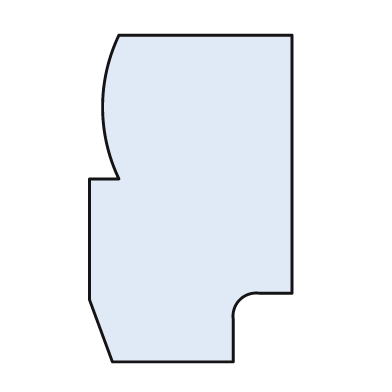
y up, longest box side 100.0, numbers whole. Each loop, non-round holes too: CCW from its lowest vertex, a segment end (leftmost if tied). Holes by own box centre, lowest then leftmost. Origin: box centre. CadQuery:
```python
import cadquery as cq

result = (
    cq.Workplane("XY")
    .moveTo(-24.0, -50.0)
    .lineTo(13.0, -50.0)
    .lineTo(13.0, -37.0)
    .threePointArc((15.0, -31.0), (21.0, -29.0))
    .lineTo(31.0, -29.0)
    .lineTo(31.0, 50.0)
    .lineTo(-22.0, 50.0)
    .threePointArc((-27.0, 28.0), (-22.0, 6.0))
    .lineTo(-31.0, 6.0)
    .lineTo(-31.0, -31.0)
    .close()
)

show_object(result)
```